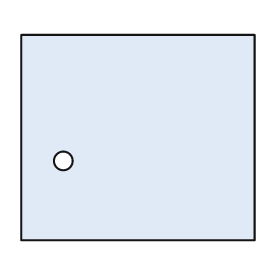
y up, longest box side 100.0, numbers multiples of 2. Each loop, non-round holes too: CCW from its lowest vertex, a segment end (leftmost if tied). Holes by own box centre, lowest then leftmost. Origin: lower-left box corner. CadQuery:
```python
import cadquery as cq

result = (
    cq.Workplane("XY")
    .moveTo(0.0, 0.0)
    .lineTo(100.0, 0.0)
    .lineTo(100.0, 88.0)
    .lineTo(0.0, 88.0)
    .close()
    .moveTo(18.0, 34.0)
    .circle(4.0)
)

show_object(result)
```